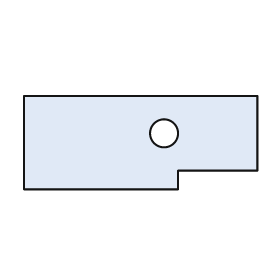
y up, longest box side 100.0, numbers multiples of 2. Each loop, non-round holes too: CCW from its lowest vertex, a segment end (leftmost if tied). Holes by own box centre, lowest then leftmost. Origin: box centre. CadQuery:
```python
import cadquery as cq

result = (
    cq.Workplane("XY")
    .moveTo(-50.0, -20.0)
    .lineTo(16.0, -20.0)
    .lineTo(16.0, -12.0)
    .lineTo(50.0, -12.0)
    .lineTo(50.0, 20.0)
    .lineTo(-50.0, 20.0)
    .close()
    .moveTo(10.0, 4.0)
    .circle(6.0)
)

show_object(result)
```